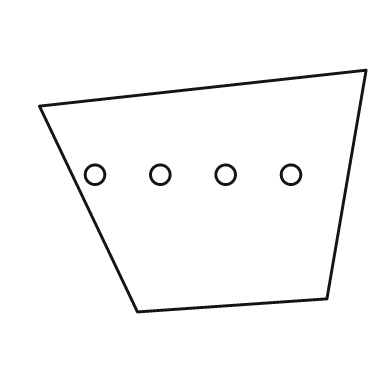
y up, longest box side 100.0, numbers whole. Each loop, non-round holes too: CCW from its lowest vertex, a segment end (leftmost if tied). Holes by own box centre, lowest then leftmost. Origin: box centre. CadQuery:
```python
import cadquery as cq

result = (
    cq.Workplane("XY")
    .moveTo(-20.0, -37.0)
    .lineTo(38.0, -33.0)
    .lineTo(50.0, 37.0)
    .lineTo(-50.0, 26.0)
    .close()
    .moveTo(-33.0, 5.0)
    .circle(3.0)
    .moveTo(-13.0, 5.0)
    .circle(3.0)
    .moveTo(7.0, 5.0)
    .circle(3.0)
    .moveTo(27.0, 5.0)
    .circle(3.0)
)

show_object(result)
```